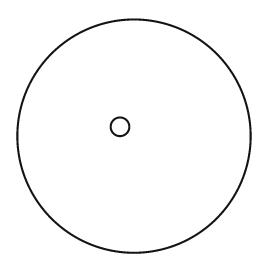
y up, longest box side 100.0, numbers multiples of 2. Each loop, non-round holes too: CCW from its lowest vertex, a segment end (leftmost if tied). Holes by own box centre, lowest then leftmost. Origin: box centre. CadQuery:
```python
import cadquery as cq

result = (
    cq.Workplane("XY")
    .moveTo(0.0, 0.0)
    .circle(50.0)
    .moveTo(-6.0, 4.0)
    .circle(4.0)
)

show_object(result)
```